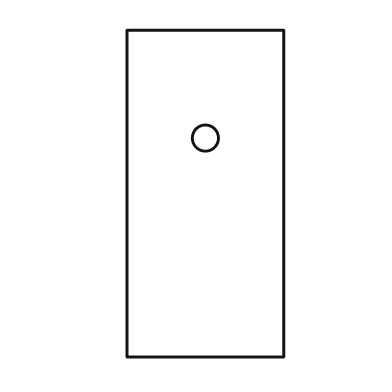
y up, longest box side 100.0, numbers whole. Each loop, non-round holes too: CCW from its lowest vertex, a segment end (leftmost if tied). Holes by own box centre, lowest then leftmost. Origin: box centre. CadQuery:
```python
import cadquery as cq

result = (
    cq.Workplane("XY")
    .moveTo(-24.0, -50.0)
    .lineTo(24.0, -50.0)
    .lineTo(24.0, 50.0)
    .lineTo(-24.0, 50.0)
    .close()
    .moveTo(0.0, 17.0)
    .circle(4.0)
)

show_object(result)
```